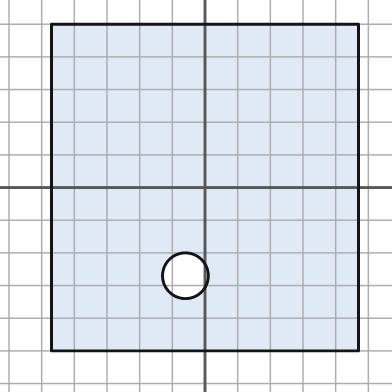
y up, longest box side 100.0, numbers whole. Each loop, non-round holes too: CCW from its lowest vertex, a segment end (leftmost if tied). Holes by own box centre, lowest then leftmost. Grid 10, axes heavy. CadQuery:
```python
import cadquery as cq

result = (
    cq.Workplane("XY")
    .moveTo(-47.0, -50.0)
    .lineTo(47.0, -50.0)
    .lineTo(47.0, 50.0)
    .lineTo(-47.0, 50.0)
    .close()
    .moveTo(-6.0, -27.0)
    .circle(7.0)
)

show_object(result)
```